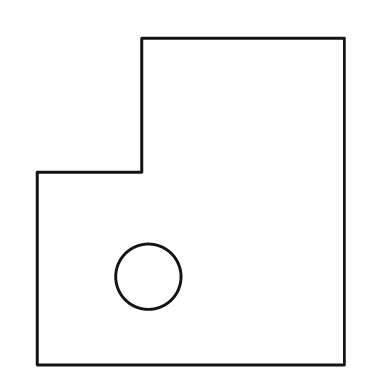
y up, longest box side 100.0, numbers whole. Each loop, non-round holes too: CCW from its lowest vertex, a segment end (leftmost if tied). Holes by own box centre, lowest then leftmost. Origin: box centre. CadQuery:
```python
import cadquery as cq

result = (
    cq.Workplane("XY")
    .moveTo(-47.0, -50.0)
    .lineTo(47.0, -50.0)
    .lineTo(47.0, 50.0)
    .lineTo(-15.0, 50.0)
    .lineTo(-15.0, 9.0)
    .lineTo(-47.0, 9.0)
    .close()
    .moveTo(-13.0, -23.0)
    .circle(10.0)
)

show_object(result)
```